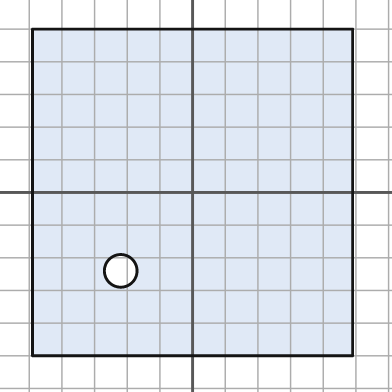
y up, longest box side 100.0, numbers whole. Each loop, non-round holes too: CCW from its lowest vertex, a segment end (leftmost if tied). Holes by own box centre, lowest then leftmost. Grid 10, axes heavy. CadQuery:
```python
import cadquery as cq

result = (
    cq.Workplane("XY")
    .moveTo(-49.0, -50.0)
    .lineTo(49.0, -50.0)
    .lineTo(49.0, 50.0)
    .lineTo(-49.0, 50.0)
    .close()
    .moveTo(-22.0, -24.0)
    .circle(5.0)
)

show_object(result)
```